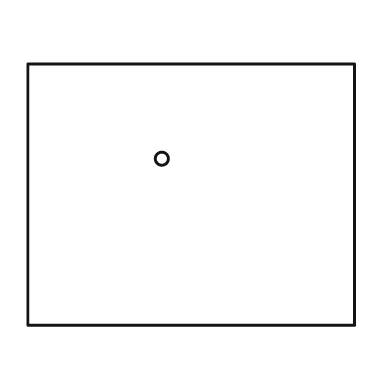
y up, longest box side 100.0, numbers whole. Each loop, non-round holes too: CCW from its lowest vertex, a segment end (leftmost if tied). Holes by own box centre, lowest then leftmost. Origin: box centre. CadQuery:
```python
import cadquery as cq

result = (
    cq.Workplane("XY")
    .moveTo(-50.0, -40.0)
    .lineTo(50.0, -40.0)
    .lineTo(50.0, 40.0)
    .lineTo(-50.0, 40.0)
    .close()
    .moveTo(-9.0, 11.0)
    .circle(2.0)
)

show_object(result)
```